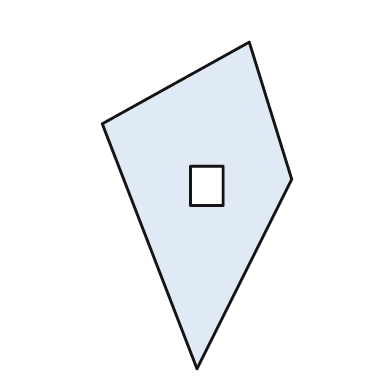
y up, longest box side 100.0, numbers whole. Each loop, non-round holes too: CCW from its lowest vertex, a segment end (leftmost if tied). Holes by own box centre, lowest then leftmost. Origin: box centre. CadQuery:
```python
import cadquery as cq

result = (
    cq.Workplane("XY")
    .moveTo(0.0, -50.0)
    .lineTo(29.0, 8.0)
    .lineTo(16.0, 50.0)
    .lineTo(-29.0, 25.0)
    .close()
    .moveTo(-2.0, 0.0)
    .lineTo(8.0, 0.0)
    .lineTo(8.0, 12.0)
    .lineTo(-2.0, 12.0)
    .close()
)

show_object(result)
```